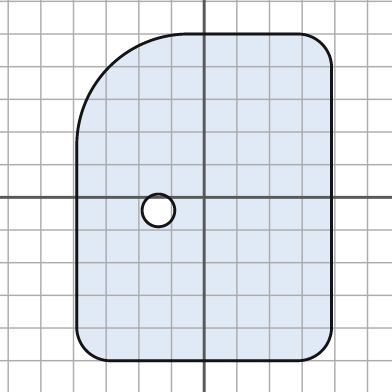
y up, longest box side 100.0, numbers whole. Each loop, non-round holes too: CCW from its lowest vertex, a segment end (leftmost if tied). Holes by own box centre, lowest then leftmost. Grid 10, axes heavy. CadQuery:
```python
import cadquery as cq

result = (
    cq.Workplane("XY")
    .moveTo(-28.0, -50.0)
    .lineTo(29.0, -50.0)
    .threePointArc((36.0, -47.0), (39.0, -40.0))
    .lineTo(39.0, 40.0)
    .threePointArc((36.0, 47.0), (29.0, 50.0))
    .lineTo(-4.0, 50.0)
    .threePointArc((-29.0, 40.0), (-39.0, 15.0))
    .lineTo(-39.0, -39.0)
    .threePointArc((-36.0, -47.0), (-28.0, -50.0))
    .close()
    .moveTo(-14.0, -4.0)
    .circle(5.0)
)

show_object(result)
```